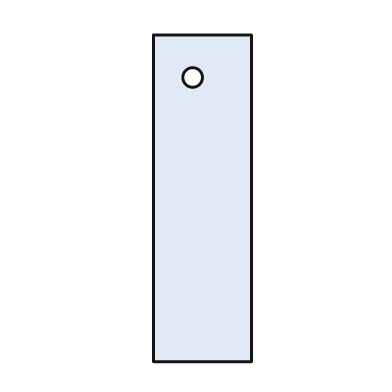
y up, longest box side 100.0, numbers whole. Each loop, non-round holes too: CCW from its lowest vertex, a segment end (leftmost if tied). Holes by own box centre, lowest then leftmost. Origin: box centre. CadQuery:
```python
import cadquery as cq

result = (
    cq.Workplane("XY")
    .moveTo(-15.0, -50.0)
    .lineTo(15.0, -50.0)
    .lineTo(15.0, 50.0)
    .lineTo(-15.0, 50.0)
    .close()
    .moveTo(-3.0, 37.0)
    .circle(3.0)
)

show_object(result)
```